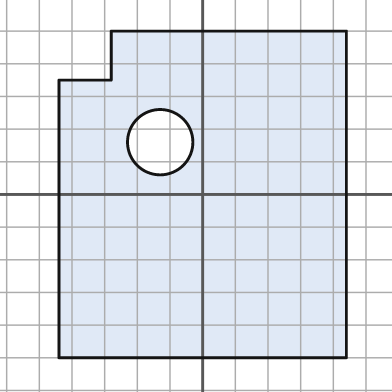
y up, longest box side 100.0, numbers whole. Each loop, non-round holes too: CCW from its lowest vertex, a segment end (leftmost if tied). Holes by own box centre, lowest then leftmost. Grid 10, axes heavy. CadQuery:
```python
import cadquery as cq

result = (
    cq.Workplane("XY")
    .moveTo(-44.0, -50.0)
    .lineTo(44.0, -50.0)
    .lineTo(44.0, 50.0)
    .lineTo(-28.0, 50.0)
    .lineTo(-28.0, 35.0)
    .lineTo(-44.0, 35.0)
    .close()
    .moveTo(-13.0, 16.0)
    .circle(10.0)
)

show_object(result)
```